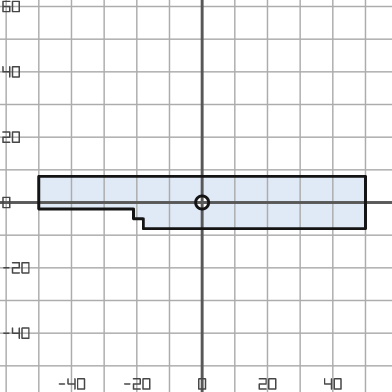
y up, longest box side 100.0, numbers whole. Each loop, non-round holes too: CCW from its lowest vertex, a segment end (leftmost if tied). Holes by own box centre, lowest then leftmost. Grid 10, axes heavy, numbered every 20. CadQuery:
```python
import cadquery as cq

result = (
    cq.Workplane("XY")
    .moveTo(-18.0, -8.0)
    .lineTo(50.0, -8.0)
    .lineTo(50.0, 8.0)
    .lineTo(-50.0, 8.0)
    .lineTo(-50.0, -2.0)
    .lineTo(-21.0, -2.0)
    .lineTo(-21.0, -5.0)
    .lineTo(-18.0, -5.0)
    .close()
    .moveTo(0.0, 0.0)
    .circle(2.0)
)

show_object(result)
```